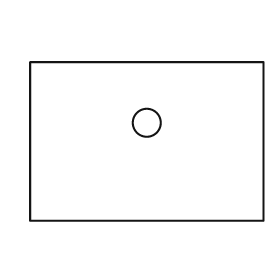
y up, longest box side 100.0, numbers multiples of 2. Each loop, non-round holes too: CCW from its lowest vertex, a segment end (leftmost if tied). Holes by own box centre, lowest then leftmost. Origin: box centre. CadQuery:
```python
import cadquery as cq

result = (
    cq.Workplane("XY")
    .moveTo(-50.0, -34.0)
    .lineTo(50.0, -34.0)
    .lineTo(50.0, 34.0)
    .lineTo(-50.0, 34.0)
    .close()
    .moveTo(0.0, 8.0)
    .circle(6.0)
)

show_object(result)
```